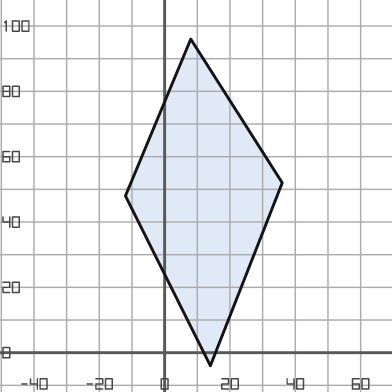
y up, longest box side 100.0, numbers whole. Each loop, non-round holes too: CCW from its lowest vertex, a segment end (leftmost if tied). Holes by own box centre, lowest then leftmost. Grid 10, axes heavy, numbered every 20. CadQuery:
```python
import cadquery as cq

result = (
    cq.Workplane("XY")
    .moveTo(14.0, -4.0)
    .lineTo(36.0, 52.0)
    .lineTo(8.0, 96.0)
    .lineTo(-12.0, 48.0)
    .close()
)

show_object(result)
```